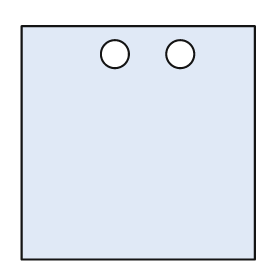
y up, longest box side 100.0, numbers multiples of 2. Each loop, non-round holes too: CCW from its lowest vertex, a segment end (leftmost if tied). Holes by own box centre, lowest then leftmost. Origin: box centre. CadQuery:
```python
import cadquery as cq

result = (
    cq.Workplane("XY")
    .moveTo(-50.0, -50.0)
    .lineTo(50.0, -50.0)
    .lineTo(50.0, 50.0)
    .lineTo(-50.0, 50.0)
    .close()
    .moveTo(-10.0, 38.0)
    .circle(6.0)
    .moveTo(18.0, 38.0)
    .circle(6.0)
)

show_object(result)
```